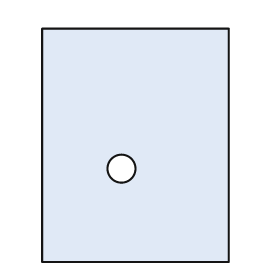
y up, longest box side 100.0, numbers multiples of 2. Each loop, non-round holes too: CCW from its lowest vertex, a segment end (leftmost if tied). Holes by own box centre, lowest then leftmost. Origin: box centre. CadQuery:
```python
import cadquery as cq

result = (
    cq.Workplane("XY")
    .moveTo(-40.0, -50.0)
    .lineTo(40.0, -50.0)
    .lineTo(40.0, 50.0)
    .lineTo(-40.0, 50.0)
    .close()
    .moveTo(-6.0, -10.0)
    .circle(6.0)
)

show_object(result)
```